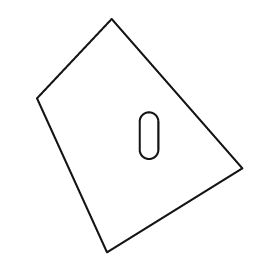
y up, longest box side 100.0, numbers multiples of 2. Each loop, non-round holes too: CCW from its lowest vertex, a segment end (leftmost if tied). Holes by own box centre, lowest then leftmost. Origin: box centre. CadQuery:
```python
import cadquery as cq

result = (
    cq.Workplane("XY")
    .moveTo(-14.0, -50.0)
    .lineTo(44.0, -14.0)
    .lineTo(-12.0, 50.0)
    .lineTo(-44.0, 16.0)
    .close()
    .moveTo(0.0, -6.0)
    .threePointArc((4.0, -10.0), (8.0, -6.0))
    .lineTo(8.0, 6.0)
    .threePointArc((4.0, 10.0), (0.0, 6.0))
    .close()
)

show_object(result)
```